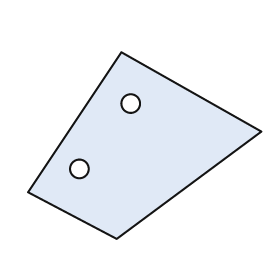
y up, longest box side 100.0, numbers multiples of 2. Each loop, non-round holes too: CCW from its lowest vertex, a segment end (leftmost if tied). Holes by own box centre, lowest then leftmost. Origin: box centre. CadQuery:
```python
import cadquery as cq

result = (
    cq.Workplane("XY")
    .moveTo(-12.0, -40.0)
    .lineTo(50.0, 6.0)
    .lineTo(-10.0, 40.0)
    .lineTo(-50.0, -20.0)
    .close()
    .moveTo(-28.0, -10.0)
    .circle(4.0)
    .moveTo(-6.0, 18.0)
    .circle(4.0)
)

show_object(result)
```